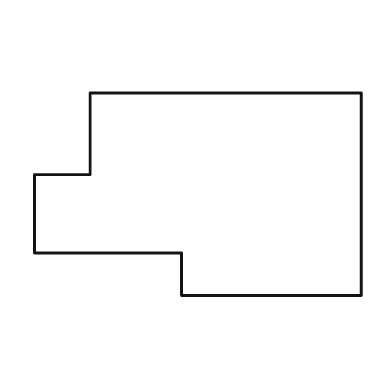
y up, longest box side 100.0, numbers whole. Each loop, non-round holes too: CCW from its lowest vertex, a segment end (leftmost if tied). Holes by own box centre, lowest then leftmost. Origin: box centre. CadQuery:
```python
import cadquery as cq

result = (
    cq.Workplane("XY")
    .moveTo(-5.0, -31.0)
    .lineTo(50.0, -31.0)
    .lineTo(50.0, 31.0)
    .lineTo(-33.0, 31.0)
    .lineTo(-33.0, 6.0)
    .lineTo(-50.0, 6.0)
    .lineTo(-50.0, -18.0)
    .lineTo(-5.0, -18.0)
    .close()
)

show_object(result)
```